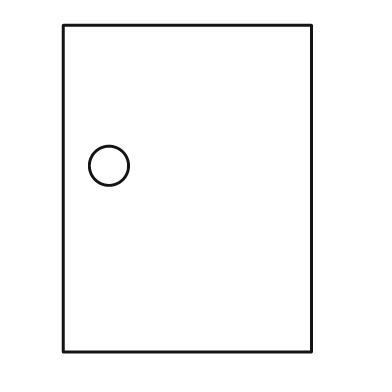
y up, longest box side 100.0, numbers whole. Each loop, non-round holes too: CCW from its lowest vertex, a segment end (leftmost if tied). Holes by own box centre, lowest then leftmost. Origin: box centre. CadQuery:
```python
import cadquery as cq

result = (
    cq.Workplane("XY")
    .moveTo(-38.0, -50.0)
    .lineTo(38.0, -50.0)
    .lineTo(38.0, 50.0)
    .lineTo(-38.0, 50.0)
    .close()
    .moveTo(-24.0, 7.0)
    .circle(6.0)
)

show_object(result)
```